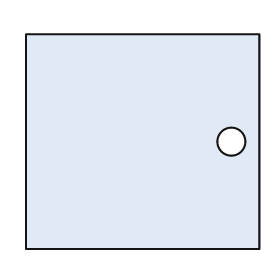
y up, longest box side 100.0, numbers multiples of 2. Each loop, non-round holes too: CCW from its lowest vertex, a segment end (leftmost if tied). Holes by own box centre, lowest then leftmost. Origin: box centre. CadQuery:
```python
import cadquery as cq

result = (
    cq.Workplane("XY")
    .moveTo(-50.0, -46.0)
    .lineTo(50.0, -46.0)
    .lineTo(50.0, 46.0)
    .lineTo(-50.0, 46.0)
    .close()
    .moveTo(38.0, 0.0)
    .circle(6.0)
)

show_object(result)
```